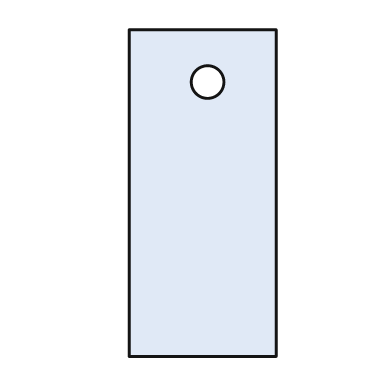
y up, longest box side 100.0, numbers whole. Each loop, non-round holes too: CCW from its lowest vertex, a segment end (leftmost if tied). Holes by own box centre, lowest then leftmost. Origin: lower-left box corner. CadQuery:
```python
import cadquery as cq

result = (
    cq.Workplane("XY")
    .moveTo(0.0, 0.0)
    .lineTo(45.0, 0.0)
    .lineTo(45.0, 100.0)
    .lineTo(0.0, 100.0)
    .close()
    .moveTo(24.0, 84.0)
    .circle(5.0)
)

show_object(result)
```